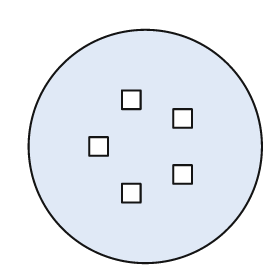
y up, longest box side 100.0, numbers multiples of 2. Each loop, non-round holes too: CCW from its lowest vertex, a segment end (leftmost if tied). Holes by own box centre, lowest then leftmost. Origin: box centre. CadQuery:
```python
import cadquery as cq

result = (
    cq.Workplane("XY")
    .moveTo(0.0, 0.0)
    .circle(50.0)
    .moveTo(-10.0, -24.0)
    .lineTo(-2.0, -24.0)
    .lineTo(-2.0, -16.0)
    .lineTo(-10.0, -16.0)
    .close()
    .moveTo(12.0, -16.0)
    .lineTo(20.0, -16.0)
    .lineTo(20.0, -8.0)
    .lineTo(12.0, -8.0)
    .close()
    .moveTo(-24.0, -4.0)
    .lineTo(-16.0, -4.0)
    .lineTo(-16.0, 4.0)
    .lineTo(-24.0, 4.0)
    .close()
    .moveTo(12.0, 8.0)
    .lineTo(20.0, 8.0)
    .lineTo(20.0, 16.0)
    .lineTo(12.0, 16.0)
    .close()
    .moveTo(-10.0, 16.0)
    .lineTo(-2.0, 16.0)
    .lineTo(-2.0, 24.0)
    .lineTo(-10.0, 24.0)
    .close()
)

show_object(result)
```